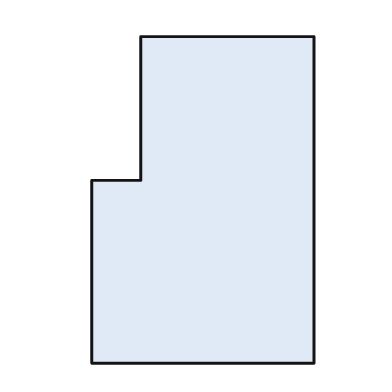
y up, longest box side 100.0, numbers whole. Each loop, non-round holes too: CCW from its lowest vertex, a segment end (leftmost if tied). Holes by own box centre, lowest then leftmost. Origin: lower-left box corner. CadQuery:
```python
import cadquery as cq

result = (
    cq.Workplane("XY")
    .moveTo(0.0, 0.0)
    .lineTo(68.0, 0.0)
    .lineTo(68.0, 100.0)
    .lineTo(15.0, 100.0)
    .lineTo(15.0, 56.0)
    .lineTo(0.0, 56.0)
    .close()
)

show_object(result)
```